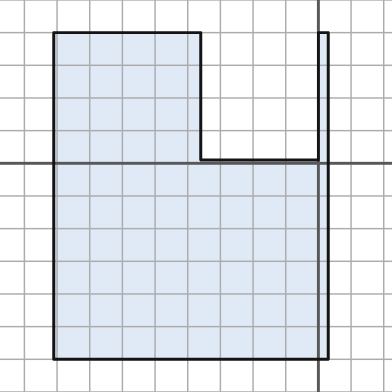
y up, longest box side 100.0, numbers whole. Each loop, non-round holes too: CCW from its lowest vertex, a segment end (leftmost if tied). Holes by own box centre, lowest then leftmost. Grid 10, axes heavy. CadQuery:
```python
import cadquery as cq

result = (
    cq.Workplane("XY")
    .moveTo(-81.0, -60.0)
    .lineTo(3.0, -60.0)
    .lineTo(3.0, 40.0)
    .lineTo(0.0, 40.0)
    .lineTo(0.0, 1.0)
    .lineTo(-36.0, 1.0)
    .lineTo(-36.0, 40.0)
    .lineTo(-81.0, 40.0)
    .close()
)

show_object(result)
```